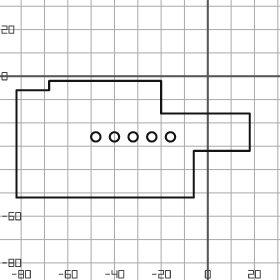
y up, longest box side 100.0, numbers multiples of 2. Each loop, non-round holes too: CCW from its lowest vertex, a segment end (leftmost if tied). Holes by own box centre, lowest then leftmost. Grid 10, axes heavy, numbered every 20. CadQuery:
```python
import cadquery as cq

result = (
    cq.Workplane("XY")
    .moveTo(-82.0, -52.0)
    .lineTo(-6.0, -52.0)
    .lineTo(-6.0, -32.0)
    .lineTo(18.0, -32.0)
    .lineTo(18.0, -16.0)
    .lineTo(-20.0, -16.0)
    .lineTo(-20.0, -2.0)
    .lineTo(-68.0, -2.0)
    .lineTo(-68.0, -6.0)
    .lineTo(-82.0, -6.0)
    .close()
    .moveTo(-48.0, -26.0)
    .circle(2.0)
    .moveTo(-40.0, -26.0)
    .circle(2.0)
    .moveTo(-32.0, -26.0)
    .circle(2.0)
    .moveTo(-24.0, -26.0)
    .circle(2.0)
    .moveTo(-16.0, -26.0)
    .circle(2.0)
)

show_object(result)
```